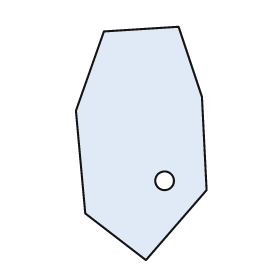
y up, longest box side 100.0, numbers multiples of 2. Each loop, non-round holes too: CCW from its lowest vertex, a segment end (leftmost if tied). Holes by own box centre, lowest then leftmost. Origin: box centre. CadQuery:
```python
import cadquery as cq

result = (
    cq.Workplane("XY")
    .moveTo(2.0, -50.0)
    .lineTo(28.0, -20.0)
    .lineTo(26.0, 20.0)
    .lineTo(16.0, 50.0)
    .lineTo(-16.0, 48.0)
    .lineTo(-28.0, 14.0)
    .lineTo(-24.0, -30.0)
    .close()
    .moveTo(10.0, -16.0)
    .circle(4.0)
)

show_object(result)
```